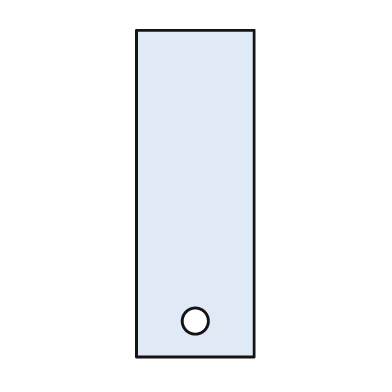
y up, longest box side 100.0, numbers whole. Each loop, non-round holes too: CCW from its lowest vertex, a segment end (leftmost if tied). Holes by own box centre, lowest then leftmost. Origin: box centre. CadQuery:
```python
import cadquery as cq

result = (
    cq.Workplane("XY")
    .moveTo(-18.0, -50.0)
    .lineTo(18.0, -50.0)
    .lineTo(18.0, 50.0)
    .lineTo(-18.0, 50.0)
    .close()
    .moveTo(0.0, -39.0)
    .circle(4.0)
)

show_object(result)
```